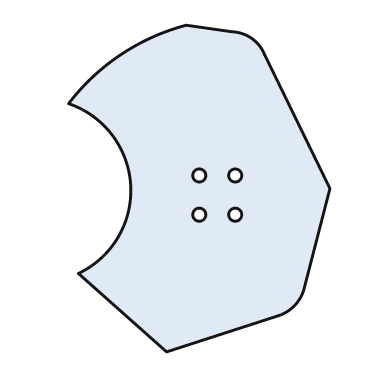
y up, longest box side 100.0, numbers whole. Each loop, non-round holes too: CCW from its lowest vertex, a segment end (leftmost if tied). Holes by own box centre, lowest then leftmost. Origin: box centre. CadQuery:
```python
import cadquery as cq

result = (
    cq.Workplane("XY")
    .moveTo(-10.0, -50.0)
    .lineTo(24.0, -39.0)
    .threePointArc((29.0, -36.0), (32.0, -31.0))
    .lineTo(40.0, 0.0)
    .lineTo(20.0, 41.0)
    .threePointArc((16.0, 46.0), (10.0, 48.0))
    .lineTo(-4.0, 50.0)
    .threePointArc((-24.0, 41.0), (-40.0, 26.0))
    .threePointArc((-21.0, 1.0), (-37.0, -26.0))
    .close()
    .moveTo(0.0, -8.0)
    .circle(2.0)
    .moveTo(11.0, -8.0)
    .circle(2.0)
    .moveTo(0.0, 4.0)
    .circle(2.0)
    .moveTo(11.0, 4.0)
    .circle(2.0)
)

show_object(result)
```